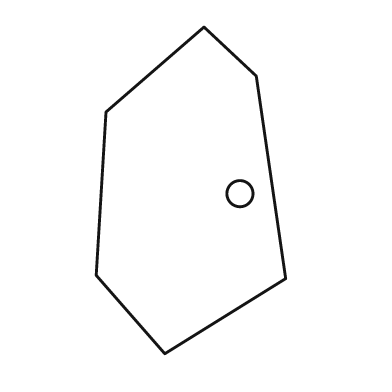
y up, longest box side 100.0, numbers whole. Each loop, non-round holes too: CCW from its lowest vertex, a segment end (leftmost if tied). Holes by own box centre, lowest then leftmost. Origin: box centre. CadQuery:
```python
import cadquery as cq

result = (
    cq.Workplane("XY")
    .moveTo(-8.0, -50.0)
    .lineTo(29.0, -27.0)
    .lineTo(20.0, 35.0)
    .lineTo(4.0, 50.0)
    .lineTo(-26.0, 24.0)
    .lineTo(-29.0, -26.0)
    .close()
    .moveTo(15.0, -1.0)
    .circle(4.0)
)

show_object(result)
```